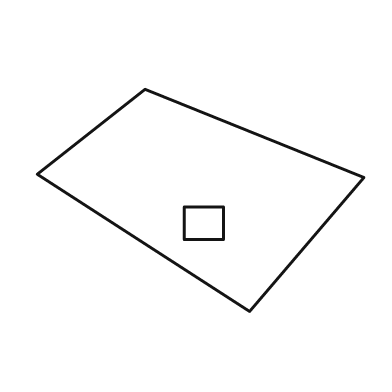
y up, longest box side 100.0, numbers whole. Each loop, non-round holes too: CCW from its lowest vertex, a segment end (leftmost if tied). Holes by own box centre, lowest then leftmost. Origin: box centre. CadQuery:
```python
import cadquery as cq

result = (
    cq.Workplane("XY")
    .moveTo(15.0, -34.0)
    .lineTo(50.0, 7.0)
    .lineTo(-17.0, 34.0)
    .lineTo(-50.0, 8.0)
    .close()
    .moveTo(-5.0, -12.0)
    .lineTo(7.0, -12.0)
    .lineTo(7.0, -2.0)
    .lineTo(-5.0, -2.0)
    .close()
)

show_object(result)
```